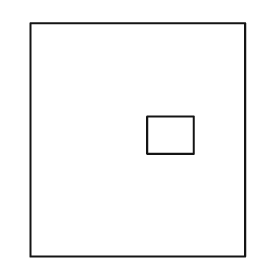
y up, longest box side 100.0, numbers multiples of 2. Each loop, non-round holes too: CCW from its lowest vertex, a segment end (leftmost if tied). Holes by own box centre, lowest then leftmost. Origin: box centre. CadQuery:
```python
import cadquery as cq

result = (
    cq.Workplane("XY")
    .moveTo(-46.0, -50.0)
    .lineTo(46.0, -50.0)
    .lineTo(46.0, 50.0)
    .lineTo(-46.0, 50.0)
    .close()
    .moveTo(4.0, -6.0)
    .lineTo(24.0, -6.0)
    .lineTo(24.0, 10.0)
    .lineTo(4.0, 10.0)
    .close()
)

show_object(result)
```